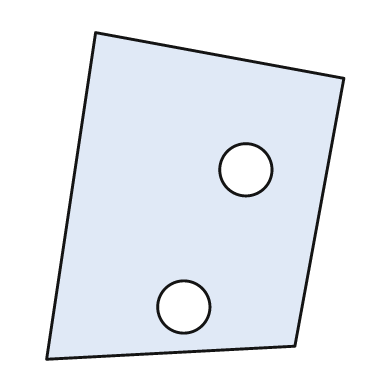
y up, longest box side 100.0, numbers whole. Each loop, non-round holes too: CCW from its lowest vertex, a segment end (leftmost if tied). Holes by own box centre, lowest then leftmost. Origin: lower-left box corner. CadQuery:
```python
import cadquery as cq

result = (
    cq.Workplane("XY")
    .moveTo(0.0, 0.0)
    .lineTo(76.0, 4.0)
    .lineTo(91.0, 86.0)
    .lineTo(15.0, 100.0)
    .close()
    .moveTo(42.0, 16.0)
    .circle(8.0)
    .moveTo(61.0, 58.0)
    .circle(8.0)
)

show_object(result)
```